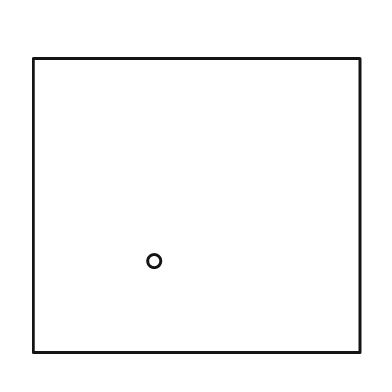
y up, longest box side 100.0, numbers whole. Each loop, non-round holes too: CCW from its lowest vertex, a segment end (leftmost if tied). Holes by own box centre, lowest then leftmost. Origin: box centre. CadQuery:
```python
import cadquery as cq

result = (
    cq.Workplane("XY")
    .moveTo(-50.0, -45.0)
    .lineTo(50.0, -45.0)
    .lineTo(50.0, 45.0)
    .lineTo(-50.0, 45.0)
    .close()
    .moveTo(-13.0, -17.0)
    .circle(2.0)
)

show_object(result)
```